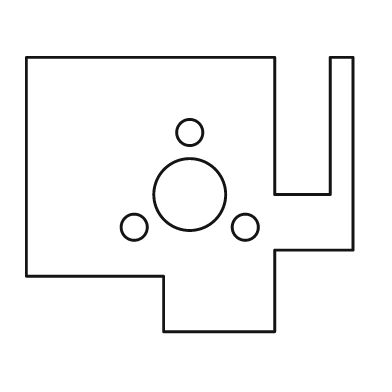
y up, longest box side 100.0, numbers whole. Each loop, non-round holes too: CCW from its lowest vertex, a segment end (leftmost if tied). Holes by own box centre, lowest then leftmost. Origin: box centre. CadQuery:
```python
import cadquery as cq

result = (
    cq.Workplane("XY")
    .moveTo(-8.0, -42.0)
    .lineTo(26.0, -42.0)
    .lineTo(26.0, -17.0)
    .lineTo(50.0, -17.0)
    .lineTo(50.0, 42.0)
    .lineTo(43.0, 42.0)
    .lineTo(43.0, 0.0)
    .lineTo(26.0, 0.0)
    .lineTo(26.0, 42.0)
    .lineTo(-50.0, 42.0)
    .lineTo(-50.0, -25.0)
    .lineTo(-8.0, -25.0)
    .close()
    .moveTo(-17.0, -10.0)
    .circle(4.0)
    .moveTo(17.0, -10.0)
    .circle(4.0)
    .moveTo(0.0, 0.0)
    .circle(11.0)
    .moveTo(0.0, 19.0)
    .circle(4.0)
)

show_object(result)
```